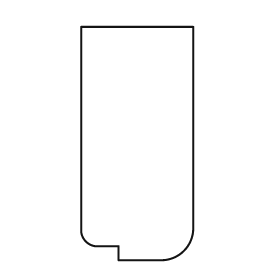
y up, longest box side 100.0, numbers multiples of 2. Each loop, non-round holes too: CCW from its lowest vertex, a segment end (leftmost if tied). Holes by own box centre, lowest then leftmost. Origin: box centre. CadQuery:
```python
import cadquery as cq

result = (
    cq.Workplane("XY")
    .moveTo(-8.0, -50.0)
    .lineTo(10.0, -50.0)
    .threePointArc((20.0, -46.0), (24.0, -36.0))
    .lineTo(24.0, 50.0)
    .lineTo(-24.0, 50.0)
    .lineTo(-24.0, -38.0)
    .threePointArc((-22.0, -42.0), (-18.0, -44.0))
    .lineTo(-8.0, -44.0)
    .close()
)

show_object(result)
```